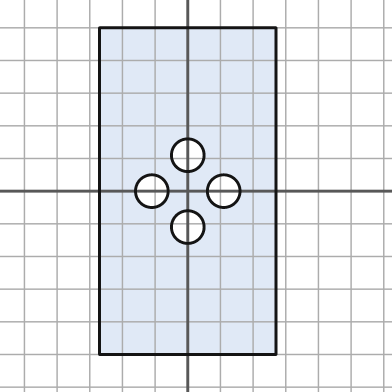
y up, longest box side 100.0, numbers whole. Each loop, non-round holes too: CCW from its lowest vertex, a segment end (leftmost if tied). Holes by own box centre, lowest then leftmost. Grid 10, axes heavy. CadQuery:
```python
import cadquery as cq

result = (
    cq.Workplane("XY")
    .moveTo(-27.0, -50.0)
    .lineTo(27.0, -50.0)
    .lineTo(27.0, 50.0)
    .lineTo(-27.0, 50.0)
    .close()
    .moveTo(0.0, -11.0)
    .circle(5.0)
    .moveTo(-11.0, 0.0)
    .circle(5.0)
    .moveTo(11.0, 0.0)
    .circle(5.0)
    .moveTo(0.0, 11.0)
    .circle(5.0)
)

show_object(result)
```